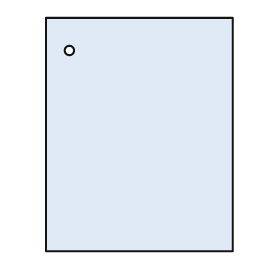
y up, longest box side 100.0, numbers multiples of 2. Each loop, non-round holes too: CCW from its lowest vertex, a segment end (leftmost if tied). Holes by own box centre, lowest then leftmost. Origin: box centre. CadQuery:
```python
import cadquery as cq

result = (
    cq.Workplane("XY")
    .moveTo(-40.0, -50.0)
    .lineTo(40.0, -50.0)
    .lineTo(40.0, 50.0)
    .lineTo(-40.0, 50.0)
    .close()
    .moveTo(-30.0, 36.0)
    .circle(2.0)
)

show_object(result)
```